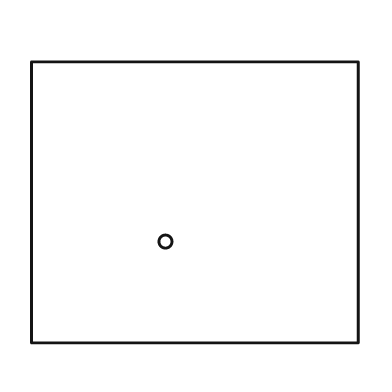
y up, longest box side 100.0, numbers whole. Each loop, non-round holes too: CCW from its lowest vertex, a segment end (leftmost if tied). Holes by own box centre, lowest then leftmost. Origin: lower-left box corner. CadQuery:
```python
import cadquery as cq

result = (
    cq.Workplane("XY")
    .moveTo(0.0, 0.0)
    .lineTo(100.0, 0.0)
    .lineTo(100.0, 86.0)
    .lineTo(0.0, 86.0)
    .close()
    .moveTo(41.0, 31.0)
    .circle(2.0)
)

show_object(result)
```